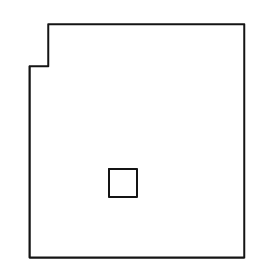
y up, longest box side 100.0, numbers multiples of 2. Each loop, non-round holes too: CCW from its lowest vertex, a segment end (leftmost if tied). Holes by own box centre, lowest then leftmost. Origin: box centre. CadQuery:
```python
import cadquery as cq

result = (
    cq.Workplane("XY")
    .moveTo(-46.0, -50.0)
    .lineTo(46.0, -50.0)
    .lineTo(46.0, 50.0)
    .lineTo(-38.0, 50.0)
    .lineTo(-38.0, 32.0)
    .lineTo(-46.0, 32.0)
    .close()
    .moveTo(-12.0, -24.0)
    .lineTo(0.0, -24.0)
    .lineTo(0.0, -12.0)
    .lineTo(-12.0, -12.0)
    .close()
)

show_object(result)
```